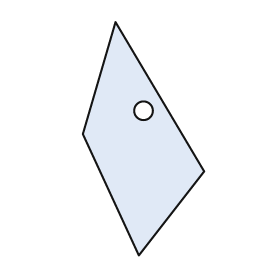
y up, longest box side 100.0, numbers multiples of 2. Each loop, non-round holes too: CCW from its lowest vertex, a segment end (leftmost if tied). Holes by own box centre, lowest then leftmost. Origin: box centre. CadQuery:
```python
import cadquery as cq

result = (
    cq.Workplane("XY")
    .moveTo(-2.0, -50.0)
    .lineTo(26.0, -14.0)
    .lineTo(-12.0, 50.0)
    .lineTo(-26.0, 2.0)
    .close()
    .moveTo(0.0, 12.0)
    .circle(4.0)
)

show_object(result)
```